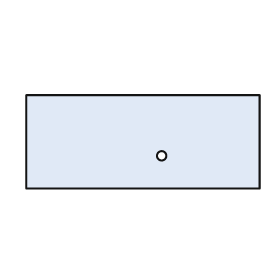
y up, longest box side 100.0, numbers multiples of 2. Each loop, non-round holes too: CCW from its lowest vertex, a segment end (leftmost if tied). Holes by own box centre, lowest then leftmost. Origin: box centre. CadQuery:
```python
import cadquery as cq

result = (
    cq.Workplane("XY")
    .moveTo(-50.0, -20.0)
    .lineTo(50.0, -20.0)
    .lineTo(50.0, 20.0)
    .lineTo(-50.0, 20.0)
    .close()
    .moveTo(8.0, -6.0)
    .circle(2.0)
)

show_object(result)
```